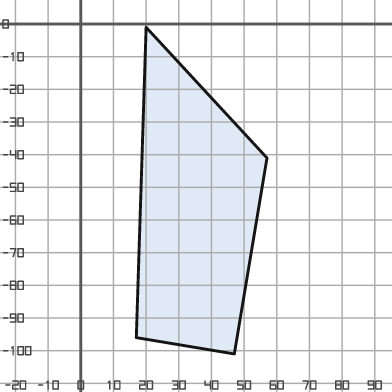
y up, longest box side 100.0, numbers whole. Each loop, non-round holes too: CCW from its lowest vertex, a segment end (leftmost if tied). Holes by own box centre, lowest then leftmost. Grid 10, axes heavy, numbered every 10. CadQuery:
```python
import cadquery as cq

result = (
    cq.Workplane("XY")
    .moveTo(47.0, -101.0)
    .lineTo(57.0, -41.0)
    .lineTo(20.0, -1.0)
    .lineTo(17.0, -96.0)
    .close()
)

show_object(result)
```